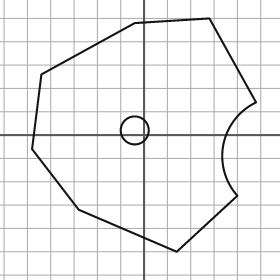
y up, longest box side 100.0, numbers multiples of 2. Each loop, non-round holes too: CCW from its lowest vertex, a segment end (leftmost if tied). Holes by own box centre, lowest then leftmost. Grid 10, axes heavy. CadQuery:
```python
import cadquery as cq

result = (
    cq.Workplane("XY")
    .moveTo(14.0, -50.0)
    .lineTo(40.0, -26.0)
    .threePointArc((34.0, -4.0), (48.0, 14.0))
    .lineTo(28.0, 50.0)
    .lineTo(-4.0, 48.0)
    .lineTo(-44.0, 26.0)
    .lineTo(-48.0, -6.0)
    .lineTo(-28.0, -32.0)
    .close()
    .moveTo(-4.0, 2.0)
    .circle(6.0)
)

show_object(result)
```